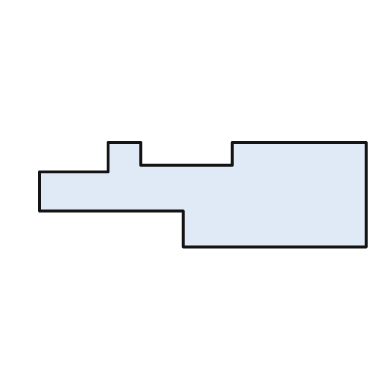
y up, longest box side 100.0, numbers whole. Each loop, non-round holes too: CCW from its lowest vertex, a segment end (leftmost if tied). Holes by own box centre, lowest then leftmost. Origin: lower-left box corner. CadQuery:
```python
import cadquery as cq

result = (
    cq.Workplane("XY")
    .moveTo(44.0, 0.0)
    .lineTo(100.0, 0.0)
    .lineTo(100.0, 32.0)
    .lineTo(59.0, 32.0)
    .lineTo(59.0, 25.0)
    .lineTo(31.0, 25.0)
    .lineTo(31.0, 32.0)
    .lineTo(21.0, 32.0)
    .lineTo(21.0, 23.0)
    .lineTo(0.0, 23.0)
    .lineTo(0.0, 11.0)
    .lineTo(44.0, 11.0)
    .close()
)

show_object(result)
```